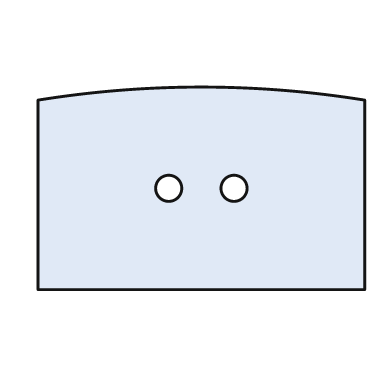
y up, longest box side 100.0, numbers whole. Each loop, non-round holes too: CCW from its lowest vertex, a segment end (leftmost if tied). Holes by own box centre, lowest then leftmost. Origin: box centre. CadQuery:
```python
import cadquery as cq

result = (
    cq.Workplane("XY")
    .moveTo(-50.0, -31.0)
    .lineTo(50.0, -31.0)
    .lineTo(50.0, 27.0)
    .threePointArc((0.0, 31.0), (-50.0, 27.0))
    .close()
    .moveTo(-10.0, 0.0)
    .circle(4.0)
    .moveTo(10.0, 0.0)
    .circle(4.0)
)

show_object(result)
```